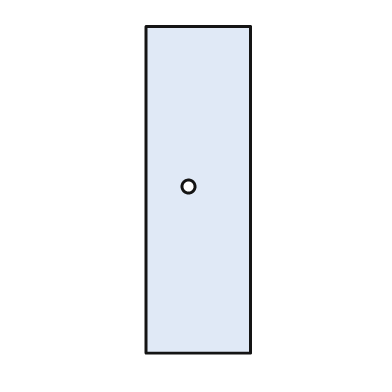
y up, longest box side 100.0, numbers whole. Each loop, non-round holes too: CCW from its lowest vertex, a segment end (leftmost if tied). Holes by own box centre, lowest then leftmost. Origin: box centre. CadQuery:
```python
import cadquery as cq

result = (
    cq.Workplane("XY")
    .moveTo(-16.0, -50.0)
    .lineTo(16.0, -50.0)
    .lineTo(16.0, 50.0)
    .lineTo(-16.0, 50.0)
    .close()
    .moveTo(-3.0, 1.0)
    .circle(2.0)
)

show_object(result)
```